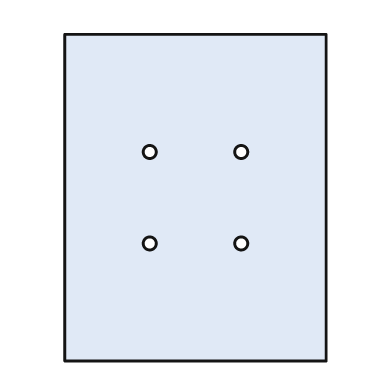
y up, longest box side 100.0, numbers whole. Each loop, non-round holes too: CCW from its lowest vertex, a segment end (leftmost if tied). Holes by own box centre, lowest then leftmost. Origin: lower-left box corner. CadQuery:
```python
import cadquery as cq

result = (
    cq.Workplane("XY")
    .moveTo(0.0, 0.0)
    .lineTo(80.0, 0.0)
    .lineTo(80.0, 100.0)
    .lineTo(0.0, 100.0)
    .close()
    .moveTo(26.0, 36.0)
    .circle(2.0)
    .moveTo(54.0, 36.0)
    .circle(2.0)
    .moveTo(26.0, 64.0)
    .circle(2.0)
    .moveTo(54.0, 64.0)
    .circle(2.0)
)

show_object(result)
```